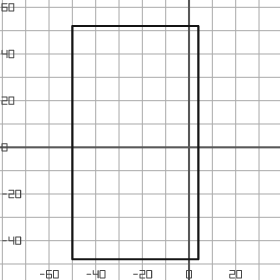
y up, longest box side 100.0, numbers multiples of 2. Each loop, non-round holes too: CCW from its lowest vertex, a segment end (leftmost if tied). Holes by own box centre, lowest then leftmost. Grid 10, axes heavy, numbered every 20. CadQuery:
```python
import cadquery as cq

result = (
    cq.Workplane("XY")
    .moveTo(-50.0, -48.0)
    .lineTo(4.0, -48.0)
    .lineTo(4.0, 52.0)
    .lineTo(-50.0, 52.0)
    .close()
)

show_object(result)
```